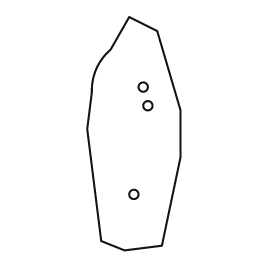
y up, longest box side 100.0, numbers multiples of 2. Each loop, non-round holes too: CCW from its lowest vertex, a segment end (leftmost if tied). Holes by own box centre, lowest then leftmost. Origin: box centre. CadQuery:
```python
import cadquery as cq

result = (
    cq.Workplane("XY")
    .moveTo(-4.0, -50.0)
    .lineTo(12.0, -48.0)
    .lineTo(20.0, -10.0)
    .lineTo(20.0, 10.0)
    .lineTo(10.0, 44.0)
    .lineTo(-2.0, 50.0)
    .lineTo(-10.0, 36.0)
    .threePointArc((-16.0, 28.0), (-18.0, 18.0))
    .lineTo(-20.0, 2.0)
    .lineTo(-14.0, -46.0)
    .close()
    .moveTo(0.0, -26.0)
    .circle(2.0)
    .moveTo(6.0, 12.0)
    .circle(2.0)
    .moveTo(4.0, 20.0)
    .circle(2.0)
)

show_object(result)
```